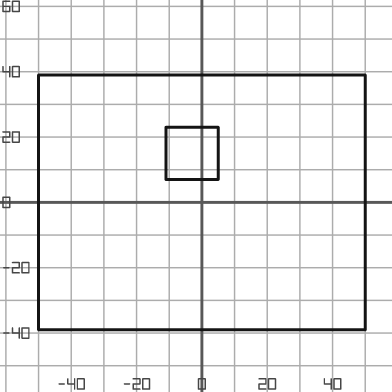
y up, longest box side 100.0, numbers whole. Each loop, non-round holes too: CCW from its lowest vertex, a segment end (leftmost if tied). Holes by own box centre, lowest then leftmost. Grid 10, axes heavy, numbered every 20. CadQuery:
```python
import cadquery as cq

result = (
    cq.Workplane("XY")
    .moveTo(-50.0, -39.0)
    .lineTo(50.0, -39.0)
    .lineTo(50.0, 39.0)
    .lineTo(-50.0, 39.0)
    .close()
    .moveTo(-11.0, 7.0)
    .lineTo(5.0, 7.0)
    .lineTo(5.0, 23.0)
    .lineTo(-11.0, 23.0)
    .close()
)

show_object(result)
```